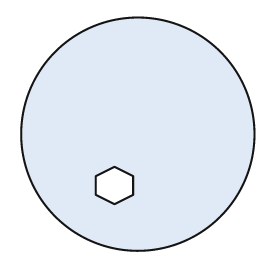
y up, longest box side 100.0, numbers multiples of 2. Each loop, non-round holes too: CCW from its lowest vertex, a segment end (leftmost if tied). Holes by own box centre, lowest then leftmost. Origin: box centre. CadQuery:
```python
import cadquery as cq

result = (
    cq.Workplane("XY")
    .moveTo(0.0, 0.0)
    .circle(50.0)
    .moveTo(-10.0, -30.0)
    .lineTo(-2.0, -26.0)
    .lineTo(-2.0, -18.0)
    .lineTo(-10.0, -14.0)
    .lineTo(-18.0, -18.0)
    .lineTo(-18.0, -26.0)
    .close()
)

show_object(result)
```